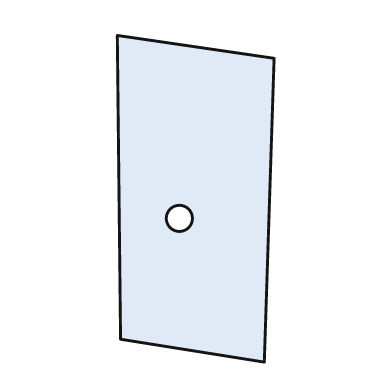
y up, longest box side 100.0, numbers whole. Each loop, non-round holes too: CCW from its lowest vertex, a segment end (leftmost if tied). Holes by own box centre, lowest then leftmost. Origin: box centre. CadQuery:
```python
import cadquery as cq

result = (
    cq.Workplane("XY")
    .moveTo(21.0, -50.0)
    .lineTo(24.0, 43.0)
    .lineTo(-24.0, 50.0)
    .lineTo(-23.0, -43.0)
    .close()
    .moveTo(-5.0, -6.0)
    .circle(4.0)
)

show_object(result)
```